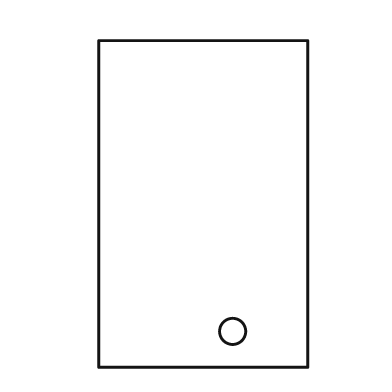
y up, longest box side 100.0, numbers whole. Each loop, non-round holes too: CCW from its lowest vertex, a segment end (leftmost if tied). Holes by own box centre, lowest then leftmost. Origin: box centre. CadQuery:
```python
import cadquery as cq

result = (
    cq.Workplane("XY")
    .moveTo(-32.0, -50.0)
    .lineTo(32.0, -50.0)
    .lineTo(32.0, 50.0)
    .lineTo(-32.0, 50.0)
    .close()
    .moveTo(9.0, -39.0)
    .circle(4.0)
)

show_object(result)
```